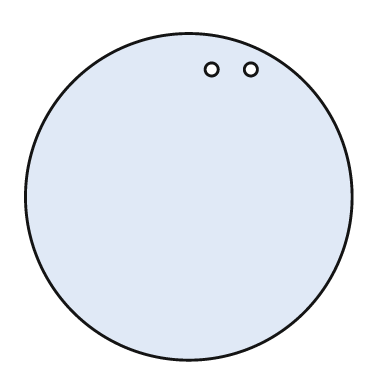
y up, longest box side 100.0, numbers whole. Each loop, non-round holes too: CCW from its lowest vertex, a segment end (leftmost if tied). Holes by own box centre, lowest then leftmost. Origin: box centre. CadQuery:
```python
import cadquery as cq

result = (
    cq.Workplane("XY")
    .moveTo(0.0, 0.0)
    .circle(50.0)
    .moveTo(7.0, 39.0)
    .circle(2.0)
    .moveTo(19.0, 39.0)
    .circle(2.0)
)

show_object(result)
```